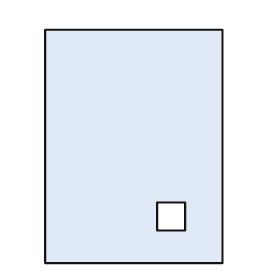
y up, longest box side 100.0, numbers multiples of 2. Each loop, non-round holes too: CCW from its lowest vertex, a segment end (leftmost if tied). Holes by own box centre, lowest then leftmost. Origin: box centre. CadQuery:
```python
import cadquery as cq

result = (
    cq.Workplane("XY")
    .moveTo(-38.0, -50.0)
    .lineTo(38.0, -50.0)
    .lineTo(38.0, 50.0)
    .lineTo(-38.0, 50.0)
    .close()
    .moveTo(10.0, -36.0)
    .lineTo(22.0, -36.0)
    .lineTo(22.0, -24.0)
    .lineTo(10.0, -24.0)
    .close()
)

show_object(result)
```